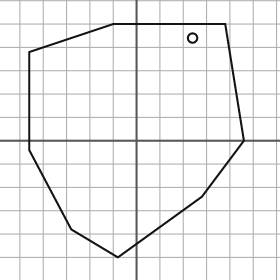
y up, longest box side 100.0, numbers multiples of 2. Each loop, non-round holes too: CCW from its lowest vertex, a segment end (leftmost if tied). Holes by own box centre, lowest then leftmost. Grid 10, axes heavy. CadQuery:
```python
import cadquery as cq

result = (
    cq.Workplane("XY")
    .moveTo(-8.0, -50.0)
    .lineTo(28.0, -24.0)
    .lineTo(46.0, 0.0)
    .lineTo(38.0, 50.0)
    .lineTo(-10.0, 50.0)
    .lineTo(-46.0, 38.0)
    .lineTo(-46.0, -4.0)
    .lineTo(-28.0, -38.0)
    .close()
    .moveTo(24.0, 44.0)
    .circle(2.0)
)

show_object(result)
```